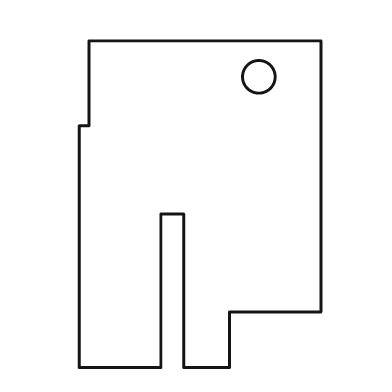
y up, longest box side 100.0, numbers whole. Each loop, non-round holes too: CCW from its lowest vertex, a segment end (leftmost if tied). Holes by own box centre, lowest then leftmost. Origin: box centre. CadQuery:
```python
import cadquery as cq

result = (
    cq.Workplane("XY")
    .moveTo(-37.0, -50.0)
    .lineTo(-12.0, -50.0)
    .lineTo(-12.0, -3.0)
    .lineTo(-5.0, -3.0)
    .lineTo(-5.0, -50.0)
    .lineTo(9.0, -50.0)
    .lineTo(9.0, -33.0)
    .lineTo(37.0, -33.0)
    .lineTo(37.0, 50.0)
    .lineTo(-34.0, 50.0)
    .lineTo(-34.0, 24.0)
    .lineTo(-37.0, 24.0)
    .close()
    .moveTo(18.0, 39.0)
    .circle(5.0)
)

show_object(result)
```